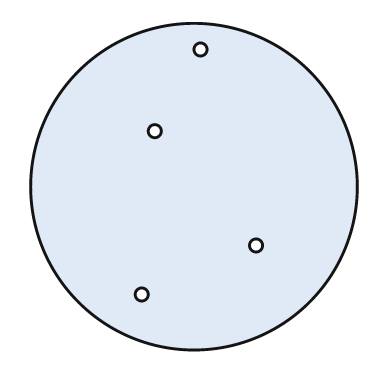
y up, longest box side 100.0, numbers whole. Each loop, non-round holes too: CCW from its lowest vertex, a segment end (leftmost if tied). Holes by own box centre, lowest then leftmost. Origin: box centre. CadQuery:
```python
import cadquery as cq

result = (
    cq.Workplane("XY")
    .moveTo(0.0, 0.0)
    .circle(50.0)
    .moveTo(-16.0, -33.0)
    .circle(2.0)
    .moveTo(19.0, -18.0)
    .circle(2.0)
    .moveTo(-12.0, 17.0)
    .circle(2.0)
    .moveTo(2.0, 42.0)
    .circle(2.0)
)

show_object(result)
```